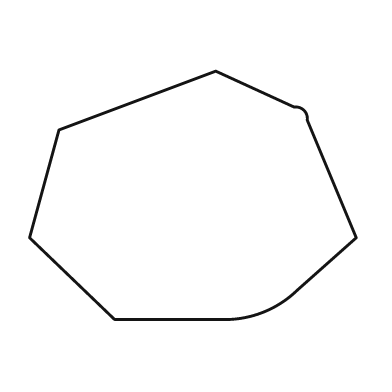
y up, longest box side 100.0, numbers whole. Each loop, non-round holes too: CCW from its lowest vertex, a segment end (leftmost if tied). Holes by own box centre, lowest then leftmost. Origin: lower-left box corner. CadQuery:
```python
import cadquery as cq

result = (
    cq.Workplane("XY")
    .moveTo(26.0, 0.0)
    .lineTo(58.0, 0.0)
    .threePointArc((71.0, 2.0), (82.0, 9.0))
    .lineTo(100.0, 25.0)
    .lineTo(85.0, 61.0)
    .threePointArc((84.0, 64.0), (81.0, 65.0))
    .lineTo(57.0, 76.0)
    .lineTo(9.0, 58.0)
    .lineTo(0.0, 25.0)
    .close()
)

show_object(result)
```